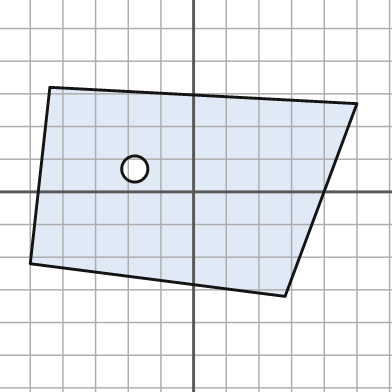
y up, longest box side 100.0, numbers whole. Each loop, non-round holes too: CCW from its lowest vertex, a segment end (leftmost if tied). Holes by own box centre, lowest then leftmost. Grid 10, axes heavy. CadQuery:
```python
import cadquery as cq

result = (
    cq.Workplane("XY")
    .moveTo(28.0, -32.0)
    .lineTo(50.0, 27.0)
    .lineTo(-44.0, 32.0)
    .lineTo(-50.0, -22.0)
    .close()
    .moveTo(-18.0, 7.0)
    .circle(4.0)
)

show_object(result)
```